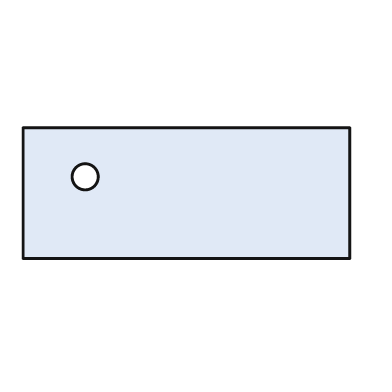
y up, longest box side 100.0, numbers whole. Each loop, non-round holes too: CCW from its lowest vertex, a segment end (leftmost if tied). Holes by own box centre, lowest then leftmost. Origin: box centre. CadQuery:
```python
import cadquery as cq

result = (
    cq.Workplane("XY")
    .moveTo(-50.0, -20.0)
    .lineTo(50.0, -20.0)
    .lineTo(50.0, 20.0)
    .lineTo(-50.0, 20.0)
    .close()
    .moveTo(-31.0, 5.0)
    .circle(4.0)
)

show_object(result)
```